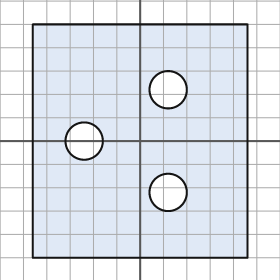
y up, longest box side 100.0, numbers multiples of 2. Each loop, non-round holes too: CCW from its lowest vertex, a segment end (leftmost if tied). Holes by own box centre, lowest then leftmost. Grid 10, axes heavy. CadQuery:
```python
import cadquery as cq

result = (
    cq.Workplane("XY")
    .moveTo(-46.0, -50.0)
    .lineTo(46.0, -50.0)
    .lineTo(46.0, 50.0)
    .lineTo(-46.0, 50.0)
    .close()
    .moveTo(12.0, -22.0)
    .circle(8.0)
    .moveTo(-24.0, 0.0)
    .circle(8.0)
    .moveTo(12.0, 22.0)
    .circle(8.0)
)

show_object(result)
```